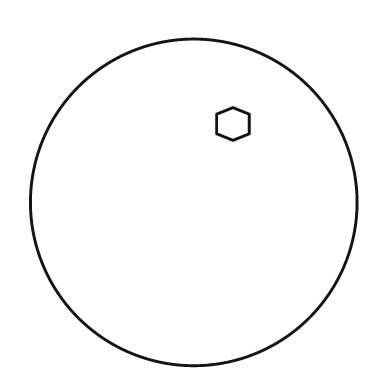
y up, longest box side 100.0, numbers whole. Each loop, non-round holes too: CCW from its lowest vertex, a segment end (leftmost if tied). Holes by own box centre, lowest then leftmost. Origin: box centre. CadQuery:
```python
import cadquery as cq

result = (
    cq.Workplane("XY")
    .moveTo(0.0, 0.0)
    .circle(50.0)
    .moveTo(12.0, 19.0)
    .lineTo(17.0, 21.0)
    .lineTo(17.0, 27.0)
    .lineTo(12.0, 29.0)
    .lineTo(7.0, 27.0)
    .lineTo(7.0, 21.0)
    .close()
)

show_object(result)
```